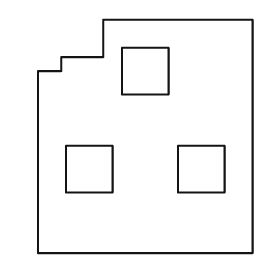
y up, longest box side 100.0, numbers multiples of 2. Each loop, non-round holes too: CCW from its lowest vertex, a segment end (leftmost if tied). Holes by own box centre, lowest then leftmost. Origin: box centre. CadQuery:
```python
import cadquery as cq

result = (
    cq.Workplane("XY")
    .moveTo(-46.0, -50.0)
    .lineTo(46.0, -50.0)
    .lineTo(46.0, 50.0)
    .lineTo(-18.0, 50.0)
    .lineTo(-18.0, 34.0)
    .lineTo(-36.0, 34.0)
    .lineTo(-36.0, 28.0)
    .lineTo(-46.0, 28.0)
    .close()
    .moveTo(-34.0, -24.0)
    .lineTo(-14.0, -24.0)
    .lineTo(-14.0, -4.0)
    .lineTo(-34.0, -4.0)
    .close()
    .moveTo(14.0, -24.0)
    .lineTo(34.0, -24.0)
    .lineTo(34.0, -4.0)
    .lineTo(14.0, -4.0)
    .close()
    .moveTo(-10.0, 18.0)
    .lineTo(10.0, 18.0)
    .lineTo(10.0, 38.0)
    .lineTo(-10.0, 38.0)
    .close()
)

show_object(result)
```